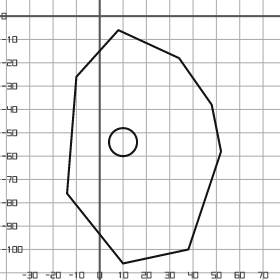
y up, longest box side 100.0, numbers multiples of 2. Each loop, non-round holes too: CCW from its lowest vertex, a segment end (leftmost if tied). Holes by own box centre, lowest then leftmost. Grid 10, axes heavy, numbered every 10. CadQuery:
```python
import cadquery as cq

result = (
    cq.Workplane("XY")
    .moveTo(10.0, -106.0)
    .lineTo(38.0, -100.0)
    .lineTo(52.0, -58.0)
    .lineTo(48.0, -38.0)
    .lineTo(34.0, -18.0)
    .lineTo(8.0, -6.0)
    .lineTo(-10.0, -26.0)
    .lineTo(-14.0, -76.0)
    .close()
    .moveTo(10.0, -54.0)
    .circle(6.0)
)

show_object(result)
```